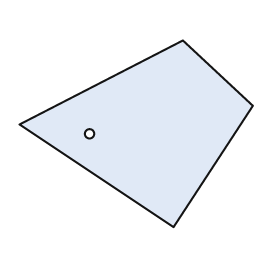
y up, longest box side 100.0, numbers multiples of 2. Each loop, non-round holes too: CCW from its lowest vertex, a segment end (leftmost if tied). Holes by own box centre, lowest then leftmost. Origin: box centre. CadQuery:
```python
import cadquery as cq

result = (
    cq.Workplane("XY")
    .moveTo(16.0, -40.0)
    .lineTo(50.0, 12.0)
    .lineTo(20.0, 40.0)
    .lineTo(-50.0, 4.0)
    .close()
    .moveTo(-20.0, 0.0)
    .circle(2.0)
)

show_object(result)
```